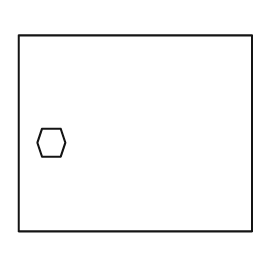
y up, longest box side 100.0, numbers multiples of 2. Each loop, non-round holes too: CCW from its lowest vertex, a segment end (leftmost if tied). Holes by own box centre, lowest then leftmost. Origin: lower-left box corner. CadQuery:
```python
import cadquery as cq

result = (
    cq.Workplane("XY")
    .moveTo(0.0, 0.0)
    .lineTo(100.0, 0.0)
    .lineTo(100.0, 84.0)
    .lineTo(0.0, 84.0)
    .close()
    .moveTo(10.0, 32.0)
    .lineTo(18.0, 32.0)
    .lineTo(20.0, 38.0)
    .lineTo(18.0, 44.0)
    .lineTo(10.0, 44.0)
    .lineTo(8.0, 38.0)
    .close()
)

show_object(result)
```